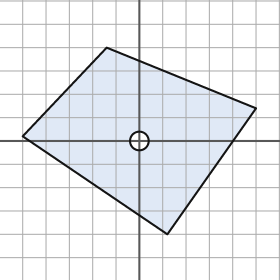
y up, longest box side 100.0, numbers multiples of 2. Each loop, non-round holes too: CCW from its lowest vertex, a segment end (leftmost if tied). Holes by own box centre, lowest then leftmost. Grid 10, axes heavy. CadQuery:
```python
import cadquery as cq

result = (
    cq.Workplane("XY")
    .moveTo(12.0, -40.0)
    .lineTo(50.0, 14.0)
    .lineTo(-14.0, 40.0)
    .lineTo(-50.0, 2.0)
    .close()
    .moveTo(0.0, 0.0)
    .circle(4.0)
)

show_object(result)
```